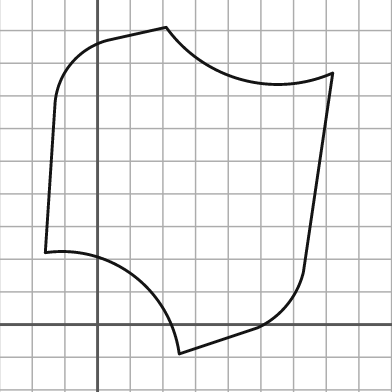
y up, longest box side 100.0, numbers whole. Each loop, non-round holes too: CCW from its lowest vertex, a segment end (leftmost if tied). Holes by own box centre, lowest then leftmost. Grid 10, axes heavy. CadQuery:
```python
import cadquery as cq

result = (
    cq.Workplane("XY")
    .moveTo(25.0, -9.0)
    .lineTo(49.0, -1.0)
    .threePointArc((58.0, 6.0), (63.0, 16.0))
    .lineTo(72.0, 77.0)
    .threePointArc((44.0, 75.0), (21.0, 91.0))
    .lineTo(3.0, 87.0)
    .threePointArc((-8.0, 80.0), (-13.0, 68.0))
    .lineTo(-16.0, 22.0)
    .threePointArc((11.0, 15.0), (25.0, -9.0))
    .close()
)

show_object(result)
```